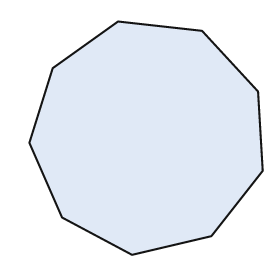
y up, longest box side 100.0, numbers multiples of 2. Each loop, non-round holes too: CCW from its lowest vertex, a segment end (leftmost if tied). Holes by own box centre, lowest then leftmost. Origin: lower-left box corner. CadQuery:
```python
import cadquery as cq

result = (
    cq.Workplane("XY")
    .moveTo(44.0, 0.0)
    .lineTo(78.0, 8.0)
    .lineTo(100.0, 36.0)
    .lineTo(98.0, 70.0)
    .lineTo(74.0, 96.0)
    .lineTo(38.0, 100.0)
    .lineTo(10.0, 80.0)
    .lineTo(0.0, 48.0)
    .lineTo(14.0, 16.0)
    .close()
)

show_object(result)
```